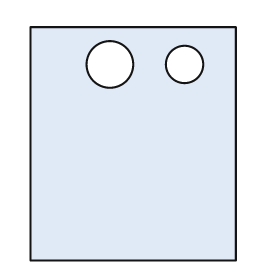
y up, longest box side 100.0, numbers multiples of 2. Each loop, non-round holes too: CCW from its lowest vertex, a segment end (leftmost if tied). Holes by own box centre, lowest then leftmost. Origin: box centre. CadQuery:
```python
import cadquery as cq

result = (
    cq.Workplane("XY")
    .moveTo(-44.0, -50.0)
    .lineTo(44.0, -50.0)
    .lineTo(44.0, 50.0)
    .lineTo(-44.0, 50.0)
    .close()
    .moveTo(-10.0, 34.0)
    .circle(10.0)
    .moveTo(22.0, 34.0)
    .circle(8.0)
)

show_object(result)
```